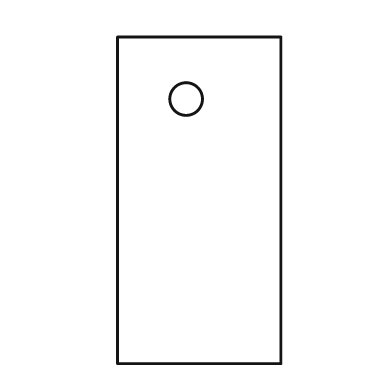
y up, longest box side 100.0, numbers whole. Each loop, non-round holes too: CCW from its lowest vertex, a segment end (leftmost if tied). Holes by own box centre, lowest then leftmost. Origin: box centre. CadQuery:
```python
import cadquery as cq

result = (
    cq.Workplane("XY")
    .moveTo(-25.0, -50.0)
    .lineTo(25.0, -50.0)
    .lineTo(25.0, 50.0)
    .lineTo(-25.0, 50.0)
    .close()
    .moveTo(-4.0, 31.0)
    .circle(5.0)
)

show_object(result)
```